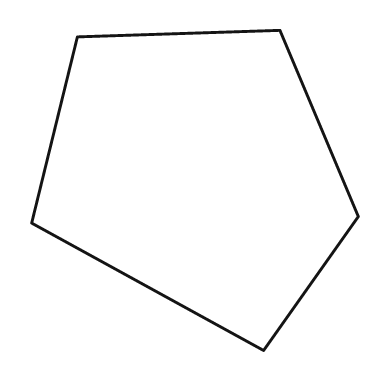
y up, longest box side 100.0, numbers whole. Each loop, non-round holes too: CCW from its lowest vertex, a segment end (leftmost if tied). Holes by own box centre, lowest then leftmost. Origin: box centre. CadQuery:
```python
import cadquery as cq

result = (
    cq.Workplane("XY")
    .moveTo(21.0, -49.0)
    .lineTo(50.0, -8.0)
    .lineTo(26.0, 49.0)
    .lineTo(-36.0, 47.0)
    .lineTo(-50.0, -10.0)
    .close()
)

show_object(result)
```